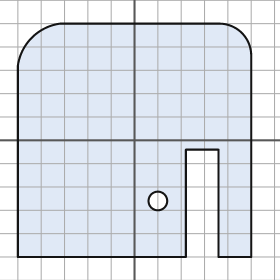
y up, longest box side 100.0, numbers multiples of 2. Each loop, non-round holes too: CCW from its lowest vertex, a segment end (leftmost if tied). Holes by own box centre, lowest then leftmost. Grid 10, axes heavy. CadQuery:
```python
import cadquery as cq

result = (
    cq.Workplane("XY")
    .moveTo(-50.0, -50.0)
    .lineTo(22.0, -50.0)
    .lineTo(22.0, -4.0)
    .lineTo(36.0, -4.0)
    .lineTo(36.0, -50.0)
    .lineTo(50.0, -50.0)
    .lineTo(50.0, 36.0)
    .threePointArc((46.0, 46.0), (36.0, 50.0))
    .lineTo(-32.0, 50.0)
    .threePointArc((-44.0, 44.0), (-50.0, 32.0))
    .close()
    .moveTo(10.0, -26.0)
    .circle(4.0)
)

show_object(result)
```